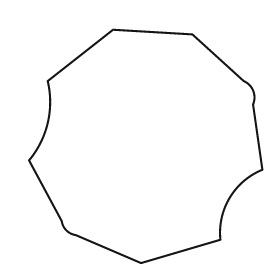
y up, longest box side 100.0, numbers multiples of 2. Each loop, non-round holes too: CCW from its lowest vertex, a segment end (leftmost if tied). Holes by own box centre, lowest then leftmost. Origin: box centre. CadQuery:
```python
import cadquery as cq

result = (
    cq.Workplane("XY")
    .moveTo(-2.0, -50.0)
    .lineTo(32.0, -40.0)
    .threePointArc((36.0, -22.0), (50.0, -10.0))
    .lineTo(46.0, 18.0)
    .threePointArc((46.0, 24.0), (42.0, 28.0))
    .lineTo(20.0, 48.0)
    .lineTo(-14.0, 50.0)
    .lineTo(-42.0, 28.0)
    .threePointArc((-42.0, 10.0), (-50.0, -6.0))
    .lineTo(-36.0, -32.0)
    .threePointArc((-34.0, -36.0), (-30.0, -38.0))
    .close()
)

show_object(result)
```